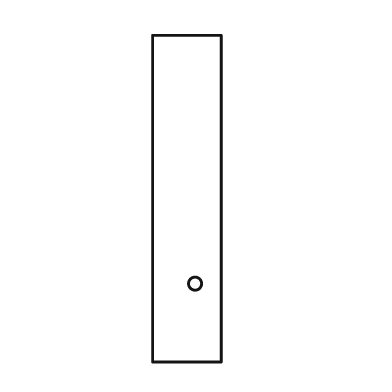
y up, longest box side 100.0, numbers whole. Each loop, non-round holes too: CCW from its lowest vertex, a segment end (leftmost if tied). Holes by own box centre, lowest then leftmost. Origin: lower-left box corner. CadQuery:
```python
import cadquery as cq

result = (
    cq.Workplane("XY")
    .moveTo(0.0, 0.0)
    .lineTo(21.0, 0.0)
    .lineTo(21.0, 100.0)
    .lineTo(0.0, 100.0)
    .close()
    .moveTo(13.0, 24.0)
    .circle(2.0)
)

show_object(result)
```